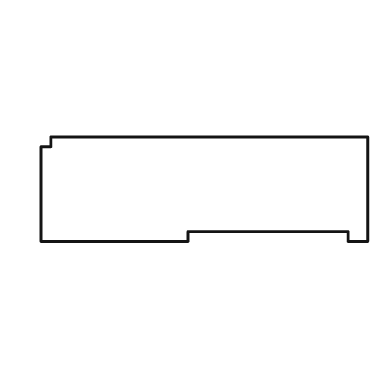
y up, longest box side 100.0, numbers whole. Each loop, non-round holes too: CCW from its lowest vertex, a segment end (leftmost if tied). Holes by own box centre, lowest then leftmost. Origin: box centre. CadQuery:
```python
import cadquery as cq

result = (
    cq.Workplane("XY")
    .moveTo(-50.0, -16.0)
    .lineTo(-5.0, -16.0)
    .lineTo(-5.0, -13.0)
    .lineTo(44.0, -13.0)
    .lineTo(44.0, -16.0)
    .lineTo(50.0, -16.0)
    .lineTo(50.0, 16.0)
    .lineTo(-47.0, 16.0)
    .lineTo(-47.0, 13.0)
    .lineTo(-50.0, 13.0)
    .close()
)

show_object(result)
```